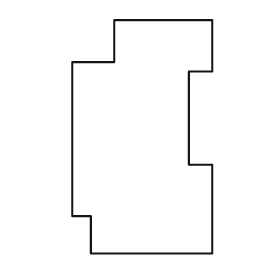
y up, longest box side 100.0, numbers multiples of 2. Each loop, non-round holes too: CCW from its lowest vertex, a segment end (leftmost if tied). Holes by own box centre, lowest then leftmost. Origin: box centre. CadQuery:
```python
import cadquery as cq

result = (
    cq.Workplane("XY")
    .moveTo(-22.0, -50.0)
    .lineTo(30.0, -50.0)
    .lineTo(30.0, -12.0)
    .lineTo(20.0, -12.0)
    .lineTo(20.0, 28.0)
    .lineTo(30.0, 28.0)
    .lineTo(30.0, 50.0)
    .lineTo(-12.0, 50.0)
    .lineTo(-12.0, 32.0)
    .lineTo(-30.0, 32.0)
    .lineTo(-30.0, -34.0)
    .lineTo(-22.0, -34.0)
    .close()
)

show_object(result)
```